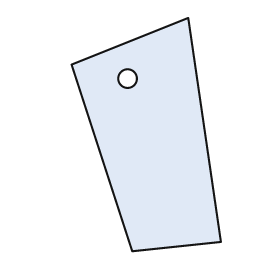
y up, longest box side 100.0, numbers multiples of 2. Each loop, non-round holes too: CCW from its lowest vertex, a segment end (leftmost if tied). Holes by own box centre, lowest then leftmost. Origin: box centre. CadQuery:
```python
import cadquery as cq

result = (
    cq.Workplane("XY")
    .moveTo(-6.0, -50.0)
    .lineTo(32.0, -46.0)
    .lineTo(18.0, 50.0)
    .lineTo(-32.0, 30.0)
    .close()
    .moveTo(-8.0, 24.0)
    .circle(4.0)
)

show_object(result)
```